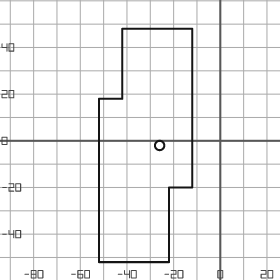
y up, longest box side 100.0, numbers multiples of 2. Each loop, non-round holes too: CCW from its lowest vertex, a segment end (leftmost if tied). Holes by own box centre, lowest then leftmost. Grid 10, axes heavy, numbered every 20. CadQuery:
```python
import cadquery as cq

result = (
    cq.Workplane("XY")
    .moveTo(-52.0, -52.0)
    .lineTo(-22.0, -52.0)
    .lineTo(-22.0, -20.0)
    .lineTo(-12.0, -20.0)
    .lineTo(-12.0, 48.0)
    .lineTo(-42.0, 48.0)
    .lineTo(-42.0, 18.0)
    .lineTo(-52.0, 18.0)
    .close()
    .moveTo(-26.0, -2.0)
    .circle(2.0)
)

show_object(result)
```